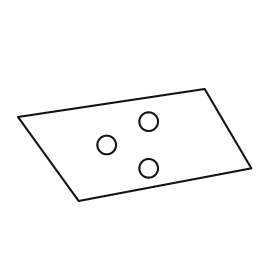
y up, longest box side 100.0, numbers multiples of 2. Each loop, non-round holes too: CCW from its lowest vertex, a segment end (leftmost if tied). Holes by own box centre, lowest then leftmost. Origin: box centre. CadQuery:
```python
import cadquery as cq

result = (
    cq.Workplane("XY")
    .moveTo(-24.0, -24.0)
    .lineTo(50.0, -10.0)
    .lineTo(30.0, 24.0)
    .lineTo(-50.0, 12.0)
    .close()
    .moveTo(6.0, -10.0)
    .circle(4.0)
    .moveTo(-12.0, 0.0)
    .circle(4.0)
    .moveTo(6.0, 10.0)
    .circle(4.0)
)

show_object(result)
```